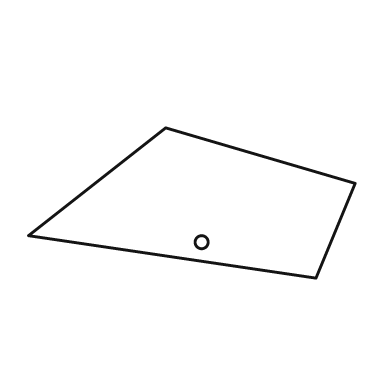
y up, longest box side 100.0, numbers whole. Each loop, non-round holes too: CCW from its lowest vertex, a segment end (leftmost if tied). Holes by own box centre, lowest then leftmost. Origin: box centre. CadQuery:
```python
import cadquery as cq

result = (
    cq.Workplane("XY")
    .moveTo(38.0, -23.0)
    .lineTo(50.0, 6.0)
    .lineTo(-8.0, 23.0)
    .lineTo(-50.0, -10.0)
    .close()
    .moveTo(3.0, -12.0)
    .circle(2.0)
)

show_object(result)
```